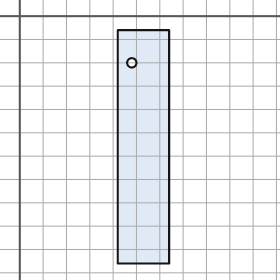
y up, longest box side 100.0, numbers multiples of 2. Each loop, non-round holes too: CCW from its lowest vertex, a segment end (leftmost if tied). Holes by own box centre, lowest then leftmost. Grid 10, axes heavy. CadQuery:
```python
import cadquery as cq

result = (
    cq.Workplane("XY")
    .moveTo(42.0, -106.0)
    .lineTo(64.0, -106.0)
    .lineTo(64.0, -6.0)
    .lineTo(42.0, -6.0)
    .close()
    .moveTo(48.0, -20.0)
    .circle(2.0)
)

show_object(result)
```